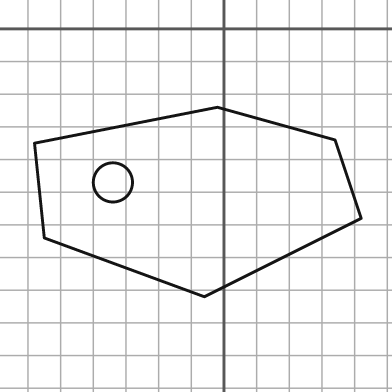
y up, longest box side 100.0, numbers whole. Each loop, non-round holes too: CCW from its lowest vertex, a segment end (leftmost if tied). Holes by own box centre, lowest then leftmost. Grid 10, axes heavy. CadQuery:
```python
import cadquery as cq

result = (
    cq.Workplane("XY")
    .moveTo(-6.0, -82.0)
    .lineTo(42.0, -58.0)
    .lineTo(34.0, -34.0)
    .lineTo(-2.0, -24.0)
    .lineTo(-58.0, -35.0)
    .lineTo(-55.0, -64.0)
    .close()
    .moveTo(-34.0, -47.0)
    .circle(6.0)
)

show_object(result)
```